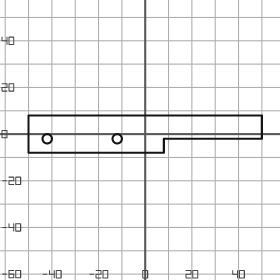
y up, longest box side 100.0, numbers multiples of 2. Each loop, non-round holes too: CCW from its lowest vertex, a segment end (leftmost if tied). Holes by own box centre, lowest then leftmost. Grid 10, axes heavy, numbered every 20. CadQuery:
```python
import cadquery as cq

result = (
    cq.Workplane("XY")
    .moveTo(-50.0, -8.0)
    .lineTo(8.0, -8.0)
    .lineTo(8.0, -2.0)
    .lineTo(50.0, -2.0)
    .lineTo(50.0, 8.0)
    .lineTo(-50.0, 8.0)
    .close()
    .moveTo(-42.0, -2.0)
    .circle(2.0)
    .moveTo(-12.0, -2.0)
    .circle(2.0)
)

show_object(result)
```